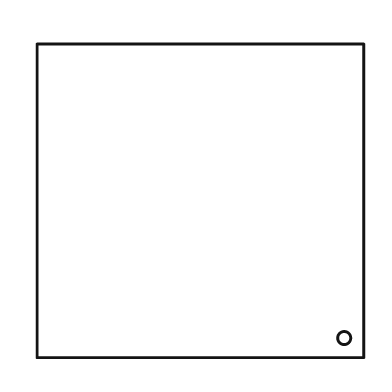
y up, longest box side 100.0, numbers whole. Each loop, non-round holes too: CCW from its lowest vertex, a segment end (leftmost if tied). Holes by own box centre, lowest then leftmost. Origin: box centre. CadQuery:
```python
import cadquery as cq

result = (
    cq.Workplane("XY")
    .moveTo(-50.0, -48.0)
    .lineTo(50.0, -48.0)
    .lineTo(50.0, 48.0)
    .lineTo(-50.0, 48.0)
    .close()
    .moveTo(44.0, -42.0)
    .circle(2.0)
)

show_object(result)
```